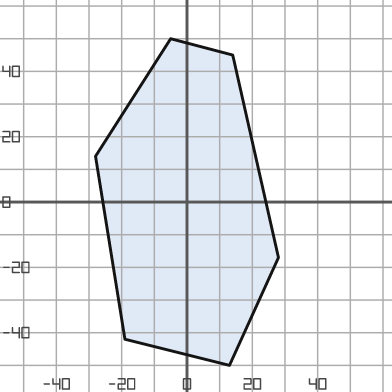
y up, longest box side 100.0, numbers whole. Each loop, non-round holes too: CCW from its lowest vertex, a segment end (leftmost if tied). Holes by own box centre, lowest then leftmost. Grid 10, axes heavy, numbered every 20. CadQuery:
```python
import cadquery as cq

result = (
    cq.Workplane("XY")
    .moveTo(13.0, -50.0)
    .lineTo(28.0, -17.0)
    .lineTo(14.0, 45.0)
    .lineTo(-5.0, 50.0)
    .lineTo(-28.0, 14.0)
    .lineTo(-19.0, -42.0)
    .close()
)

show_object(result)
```